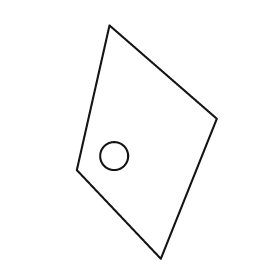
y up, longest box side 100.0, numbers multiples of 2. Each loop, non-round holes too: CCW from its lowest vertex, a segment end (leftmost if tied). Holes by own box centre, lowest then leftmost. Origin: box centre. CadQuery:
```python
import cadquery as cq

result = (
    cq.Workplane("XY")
    .moveTo(6.0, -50.0)
    .lineTo(30.0, 10.0)
    .lineTo(-16.0, 50.0)
    .lineTo(-30.0, -12.0)
    .close()
    .moveTo(-14.0, -6.0)
    .circle(6.0)
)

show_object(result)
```